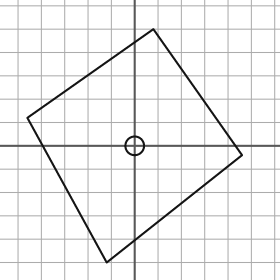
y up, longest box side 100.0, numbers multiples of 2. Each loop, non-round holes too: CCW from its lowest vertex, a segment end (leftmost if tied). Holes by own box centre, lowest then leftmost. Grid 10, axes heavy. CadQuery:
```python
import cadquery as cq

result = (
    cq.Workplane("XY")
    .moveTo(-12.0, -50.0)
    .lineTo(46.0, -4.0)
    .lineTo(8.0, 50.0)
    .lineTo(-46.0, 12.0)
    .close()
    .moveTo(0.0, 0.0)
    .circle(4.0)
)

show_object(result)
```